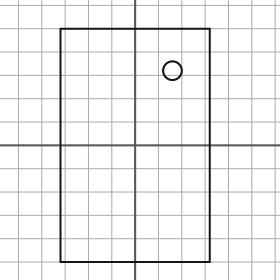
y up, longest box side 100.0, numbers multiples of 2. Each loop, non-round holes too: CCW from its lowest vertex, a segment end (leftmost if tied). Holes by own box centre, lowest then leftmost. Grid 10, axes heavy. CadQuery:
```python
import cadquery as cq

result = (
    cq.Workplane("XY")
    .moveTo(-32.0, -50.0)
    .lineTo(32.0, -50.0)
    .lineTo(32.0, 50.0)
    .lineTo(-32.0, 50.0)
    .close()
    .moveTo(16.0, 32.0)
    .circle(4.0)
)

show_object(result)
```